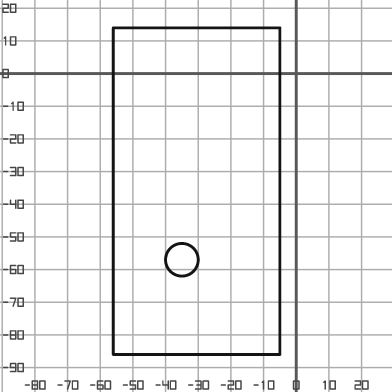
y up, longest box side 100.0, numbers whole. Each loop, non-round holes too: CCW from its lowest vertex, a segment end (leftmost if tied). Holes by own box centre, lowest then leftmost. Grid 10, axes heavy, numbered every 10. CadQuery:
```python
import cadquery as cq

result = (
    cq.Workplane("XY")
    .moveTo(-56.0, -86.0)
    .lineTo(-5.0, -86.0)
    .lineTo(-5.0, 14.0)
    .lineTo(-56.0, 14.0)
    .close()
    .moveTo(-35.0, -57.0)
    .circle(5.0)
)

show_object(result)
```